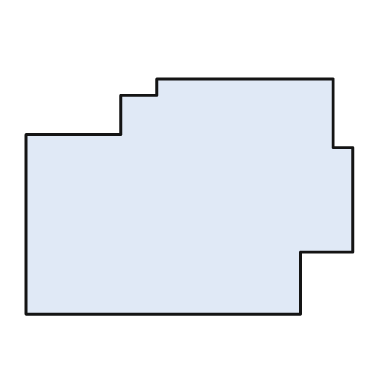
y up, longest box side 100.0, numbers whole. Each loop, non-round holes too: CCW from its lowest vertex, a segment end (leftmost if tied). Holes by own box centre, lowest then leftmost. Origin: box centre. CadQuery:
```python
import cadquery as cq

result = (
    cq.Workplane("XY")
    .moveTo(-50.0, -36.0)
    .lineTo(34.0, -36.0)
    .lineTo(34.0, -17.0)
    .lineTo(50.0, -17.0)
    .lineTo(50.0, 15.0)
    .lineTo(44.0, 15.0)
    .lineTo(44.0, 36.0)
    .lineTo(-10.0, 36.0)
    .lineTo(-10.0, 31.0)
    .lineTo(-21.0, 31.0)
    .lineTo(-21.0, 19.0)
    .lineTo(-50.0, 19.0)
    .close()
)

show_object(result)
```